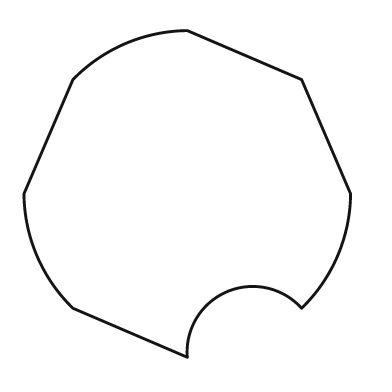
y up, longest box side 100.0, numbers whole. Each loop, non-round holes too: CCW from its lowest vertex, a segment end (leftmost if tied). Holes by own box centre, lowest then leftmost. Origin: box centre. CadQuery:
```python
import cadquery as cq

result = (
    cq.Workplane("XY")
    .moveTo(0.0, -50.0)
    .threePointArc((12.0, -30.0), (35.0, -35.0))
    .threePointArc((46.0, -19.0), (50.0, 0.0))
    .lineTo(35.0, 35.0)
    .lineTo(0.0, 50.0)
    .threePointArc((-19.0, 46.0), (-35.0, 35.0))
    .lineTo(-50.0, 0.0)
    .threePointArc((-46.0, -19.0), (-35.0, -35.0))
    .close()
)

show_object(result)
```